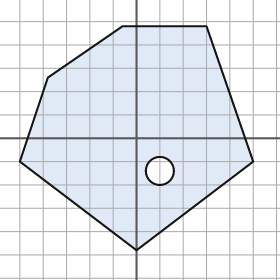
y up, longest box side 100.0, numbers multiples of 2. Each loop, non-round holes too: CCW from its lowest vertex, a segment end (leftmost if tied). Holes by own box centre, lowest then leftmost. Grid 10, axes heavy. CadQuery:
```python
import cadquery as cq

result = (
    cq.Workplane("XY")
    .moveTo(0.0, -48.0)
    .lineTo(50.0, -10.0)
    .lineTo(30.0, 48.0)
    .lineTo(-6.0, 48.0)
    .lineTo(-38.0, 26.0)
    .lineTo(-50.0, -10.0)
    .close()
    .moveTo(10.0, -14.0)
    .circle(6.0)
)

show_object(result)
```